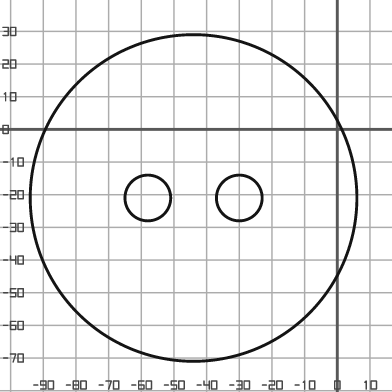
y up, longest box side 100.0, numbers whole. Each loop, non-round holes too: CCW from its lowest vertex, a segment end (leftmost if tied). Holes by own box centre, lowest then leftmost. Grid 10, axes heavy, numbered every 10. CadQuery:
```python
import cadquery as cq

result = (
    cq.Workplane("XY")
    .moveTo(-44.0, -21.0)
    .circle(50.0)
    .moveTo(-58.0, -21.0)
    .circle(7.0)
    .moveTo(-30.0, -21.0)
    .circle(7.0)
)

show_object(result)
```